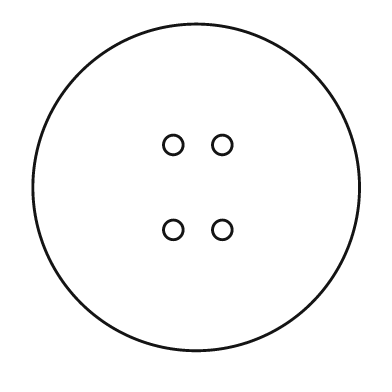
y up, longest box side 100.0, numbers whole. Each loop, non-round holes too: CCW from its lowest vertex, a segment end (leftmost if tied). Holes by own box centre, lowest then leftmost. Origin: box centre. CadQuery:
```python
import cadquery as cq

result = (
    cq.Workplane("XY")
    .moveTo(0.0, 0.0)
    .circle(50.0)
    .moveTo(-7.0, -13.0)
    .circle(3.0)
    .moveTo(8.0, -13.0)
    .circle(3.0)
    .moveTo(-7.0, 13.0)
    .circle(3.0)
    .moveTo(8.0, 13.0)
    .circle(3.0)
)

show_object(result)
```